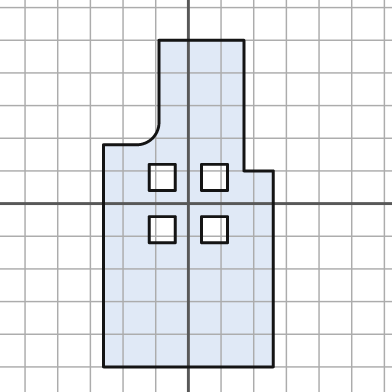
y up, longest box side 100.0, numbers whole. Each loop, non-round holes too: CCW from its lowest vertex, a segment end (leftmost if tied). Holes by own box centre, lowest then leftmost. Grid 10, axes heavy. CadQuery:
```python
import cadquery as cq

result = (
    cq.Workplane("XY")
    .moveTo(-26.0, -50.0)
    .lineTo(26.0, -50.0)
    .lineTo(26.0, 10.0)
    .lineTo(17.0, 10.0)
    .lineTo(17.0, 50.0)
    .lineTo(-9.0, 50.0)
    .lineTo(-9.0, 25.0)
    .threePointArc((-11.0, 20.0), (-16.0, 18.0))
    .lineTo(-26.0, 18.0)
    .close()
    .moveTo(-12.0, -12.0)
    .lineTo(-4.0, -12.0)
    .lineTo(-4.0, -4.0)
    .lineTo(-12.0, -4.0)
    .close()
    .moveTo(4.0, -12.0)
    .lineTo(12.0, -12.0)
    .lineTo(12.0, -4.0)
    .lineTo(4.0, -4.0)
    .close()
    .moveTo(-12.0, 4.0)
    .lineTo(-4.0, 4.0)
    .lineTo(-4.0, 12.0)
    .lineTo(-12.0, 12.0)
    .close()
    .moveTo(4.0, 4.0)
    .lineTo(12.0, 4.0)
    .lineTo(12.0, 12.0)
    .lineTo(4.0, 12.0)
    .close()
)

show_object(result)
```